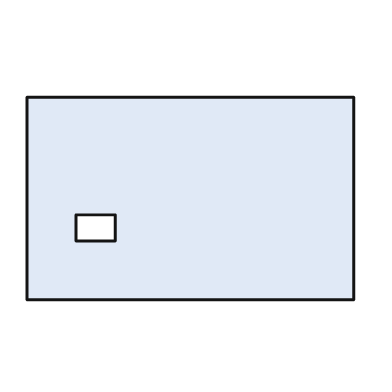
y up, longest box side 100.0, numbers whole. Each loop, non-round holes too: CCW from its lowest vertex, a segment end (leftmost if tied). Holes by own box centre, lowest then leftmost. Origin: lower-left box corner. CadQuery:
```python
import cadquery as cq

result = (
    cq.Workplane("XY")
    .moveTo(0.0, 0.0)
    .lineTo(100.0, 0.0)
    .lineTo(100.0, 62.0)
    .lineTo(0.0, 62.0)
    .close()
    .moveTo(15.0, 18.0)
    .lineTo(27.0, 18.0)
    .lineTo(27.0, 26.0)
    .lineTo(15.0, 26.0)
    .close()
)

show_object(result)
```